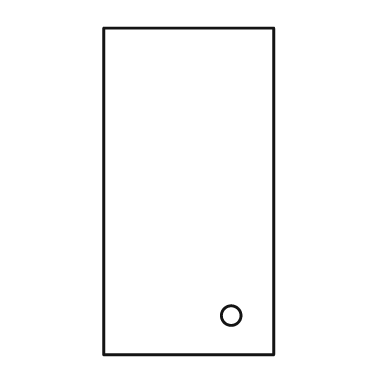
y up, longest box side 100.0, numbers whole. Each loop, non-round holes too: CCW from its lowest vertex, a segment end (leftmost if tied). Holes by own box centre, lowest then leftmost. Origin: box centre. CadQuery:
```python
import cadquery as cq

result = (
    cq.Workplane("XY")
    .moveTo(-26.0, -50.0)
    .lineTo(26.0, -50.0)
    .lineTo(26.0, 50.0)
    .lineTo(-26.0, 50.0)
    .close()
    .moveTo(13.0, -38.0)
    .circle(3.0)
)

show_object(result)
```